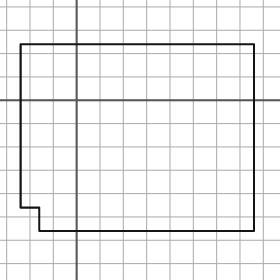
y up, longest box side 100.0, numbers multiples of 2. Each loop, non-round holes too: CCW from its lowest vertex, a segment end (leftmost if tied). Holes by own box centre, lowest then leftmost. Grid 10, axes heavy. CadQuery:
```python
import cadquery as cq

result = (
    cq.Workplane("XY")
    .moveTo(-16.0, -56.0)
    .lineTo(76.0, -56.0)
    .lineTo(76.0, 24.0)
    .lineTo(-24.0, 24.0)
    .lineTo(-24.0, -46.0)
    .lineTo(-16.0, -46.0)
    .close()
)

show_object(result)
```